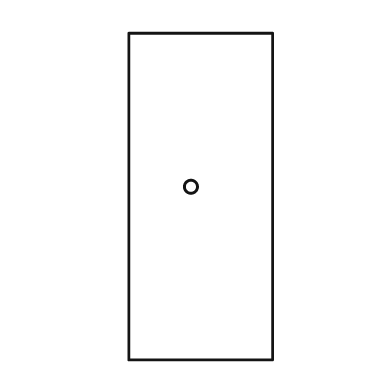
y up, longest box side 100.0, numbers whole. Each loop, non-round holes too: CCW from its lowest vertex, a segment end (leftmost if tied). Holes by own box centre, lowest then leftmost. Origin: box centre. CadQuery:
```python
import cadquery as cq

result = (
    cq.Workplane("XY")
    .moveTo(-22.0, -50.0)
    .lineTo(22.0, -50.0)
    .lineTo(22.0, 50.0)
    .lineTo(-22.0, 50.0)
    .close()
    .moveTo(-3.0, 3.0)
    .circle(2.0)
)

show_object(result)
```